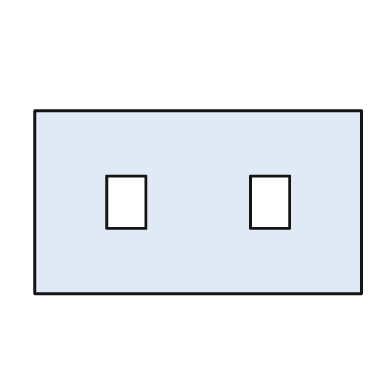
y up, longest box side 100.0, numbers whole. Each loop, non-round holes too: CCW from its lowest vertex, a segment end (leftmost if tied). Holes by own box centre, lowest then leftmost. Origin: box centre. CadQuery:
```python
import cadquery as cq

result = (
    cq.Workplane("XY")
    .moveTo(-50.0, -28.0)
    .lineTo(50.0, -28.0)
    .lineTo(50.0, 28.0)
    .lineTo(-50.0, 28.0)
    .close()
    .moveTo(-28.0, -8.0)
    .lineTo(-16.0, -8.0)
    .lineTo(-16.0, 8.0)
    .lineTo(-28.0, 8.0)
    .close()
    .moveTo(16.0, -8.0)
    .lineTo(28.0, -8.0)
    .lineTo(28.0, 8.0)
    .lineTo(16.0, 8.0)
    .close()
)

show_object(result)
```